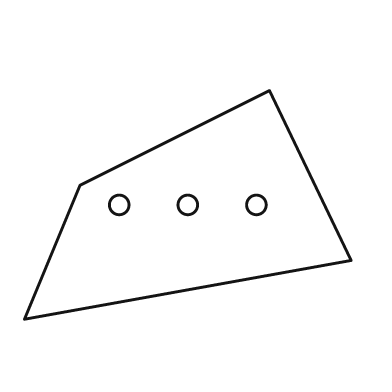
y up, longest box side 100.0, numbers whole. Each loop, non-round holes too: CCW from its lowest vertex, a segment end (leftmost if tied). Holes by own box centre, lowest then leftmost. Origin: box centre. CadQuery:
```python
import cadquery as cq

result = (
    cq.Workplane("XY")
    .moveTo(-50.0, -35.0)
    .lineTo(50.0, -17.0)
    .lineTo(25.0, 35.0)
    .lineTo(-33.0, 6.0)
    .close()
    .moveTo(-21.0, 0.0)
    .circle(3.0)
    .moveTo(0.0, 0.0)
    .circle(3.0)
    .moveTo(21.0, 0.0)
    .circle(3.0)
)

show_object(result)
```